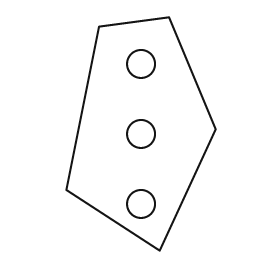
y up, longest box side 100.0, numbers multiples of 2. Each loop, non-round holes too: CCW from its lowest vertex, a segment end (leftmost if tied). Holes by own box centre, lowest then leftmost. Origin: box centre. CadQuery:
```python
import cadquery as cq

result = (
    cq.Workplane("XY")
    .moveTo(8.0, -50.0)
    .lineTo(32.0, 2.0)
    .lineTo(12.0, 50.0)
    .lineTo(-18.0, 46.0)
    .lineTo(-32.0, -24.0)
    .close()
    .moveTo(0.0, -30.0)
    .circle(6.0)
    .moveTo(0.0, 0.0)
    .circle(6.0)
    .moveTo(0.0, 30.0)
    .circle(6.0)
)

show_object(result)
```